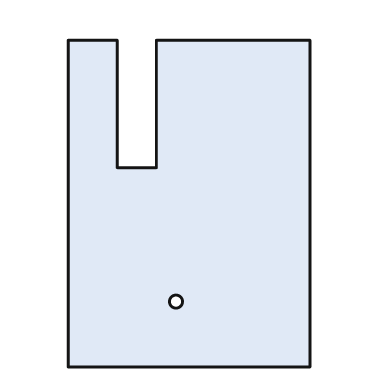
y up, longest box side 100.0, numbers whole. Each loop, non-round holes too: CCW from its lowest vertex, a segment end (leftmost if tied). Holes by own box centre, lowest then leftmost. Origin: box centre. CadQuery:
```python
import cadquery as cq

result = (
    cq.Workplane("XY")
    .moveTo(-37.0, -50.0)
    .lineTo(37.0, -50.0)
    .lineTo(37.0, 50.0)
    .lineTo(-10.0, 50.0)
    .lineTo(-10.0, 11.0)
    .lineTo(-22.0, 11.0)
    .lineTo(-22.0, 50.0)
    .lineTo(-37.0, 50.0)
    .close()
    .moveTo(-4.0, -30.0)
    .circle(2.0)
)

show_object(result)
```